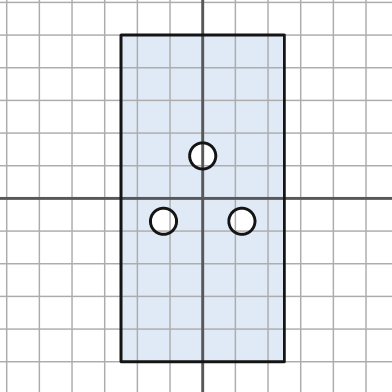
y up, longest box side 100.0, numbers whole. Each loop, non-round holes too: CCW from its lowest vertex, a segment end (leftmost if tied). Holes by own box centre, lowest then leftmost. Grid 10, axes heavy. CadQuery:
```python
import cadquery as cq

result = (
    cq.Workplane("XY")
    .moveTo(-25.0, -50.0)
    .lineTo(25.0, -50.0)
    .lineTo(25.0, 50.0)
    .lineTo(-25.0, 50.0)
    .close()
    .moveTo(-12.0, -7.0)
    .circle(4.0)
    .moveTo(12.0, -7.0)
    .circle(4.0)
    .moveTo(0.0, 13.0)
    .circle(4.0)
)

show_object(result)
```